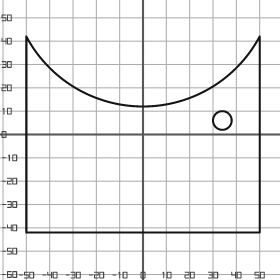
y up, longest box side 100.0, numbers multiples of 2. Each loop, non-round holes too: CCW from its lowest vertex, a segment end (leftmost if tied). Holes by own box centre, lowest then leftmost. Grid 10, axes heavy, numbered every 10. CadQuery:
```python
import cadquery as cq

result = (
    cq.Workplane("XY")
    .moveTo(-50.0, -42.0)
    .lineTo(50.0, -42.0)
    .lineTo(50.0, 42.0)
    .threePointArc((0.0, 12.0), (-50.0, 42.0))
    .close()
    .moveTo(34.0, 6.0)
    .circle(4.0)
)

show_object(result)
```